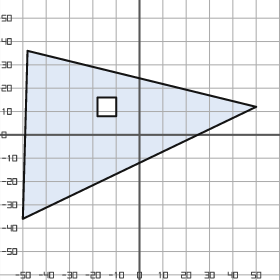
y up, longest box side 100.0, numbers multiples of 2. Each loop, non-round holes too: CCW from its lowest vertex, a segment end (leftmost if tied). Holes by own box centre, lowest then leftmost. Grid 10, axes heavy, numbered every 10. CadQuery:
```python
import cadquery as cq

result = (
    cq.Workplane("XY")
    .moveTo(-50.0, -36.0)
    .lineTo(50.0, 12.0)
    .lineTo(-48.0, 36.0)
    .close()
    .moveTo(-18.0, 8.0)
    .lineTo(-10.0, 8.0)
    .lineTo(-10.0, 16.0)
    .lineTo(-18.0, 16.0)
    .close()
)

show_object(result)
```